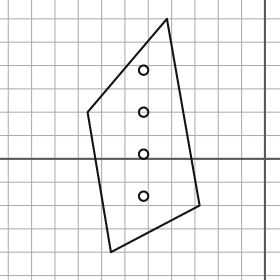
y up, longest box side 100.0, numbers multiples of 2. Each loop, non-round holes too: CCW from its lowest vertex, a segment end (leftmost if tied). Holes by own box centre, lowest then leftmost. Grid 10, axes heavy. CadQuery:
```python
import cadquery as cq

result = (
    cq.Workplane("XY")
    .moveTo(-66.0, -40.0)
    .lineTo(-28.0, -20.0)
    .lineTo(-42.0, 60.0)
    .lineTo(-76.0, 20.0)
    .close()
    .moveTo(-52.0, -16.0)
    .circle(2.0)
    .moveTo(-52.0, 2.0)
    .circle(2.0)
    .moveTo(-52.0, 20.0)
    .circle(2.0)
    .moveTo(-52.0, 38.0)
    .circle(2.0)
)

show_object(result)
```